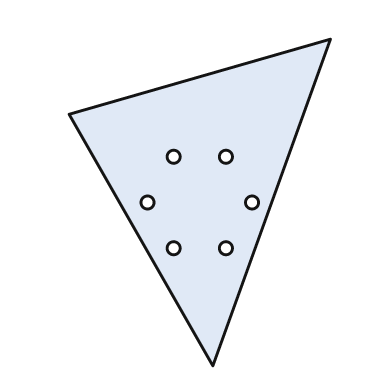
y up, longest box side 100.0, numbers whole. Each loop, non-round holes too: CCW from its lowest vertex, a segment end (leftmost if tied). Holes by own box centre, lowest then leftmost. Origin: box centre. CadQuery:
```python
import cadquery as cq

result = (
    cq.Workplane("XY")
    .moveTo(4.0, -50.0)
    .lineTo(40.0, 50.0)
    .lineTo(-40.0, 27.0)
    .close()
    .moveTo(-8.0, -14.0)
    .circle(2.0)
    .moveTo(8.0, -14.0)
    .circle(2.0)
    .moveTo(-16.0, 0.0)
    .circle(2.0)
    .moveTo(16.0, 0.0)
    .circle(2.0)
    .moveTo(-8.0, 14.0)
    .circle(2.0)
    .moveTo(8.0, 14.0)
    .circle(2.0)
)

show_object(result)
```